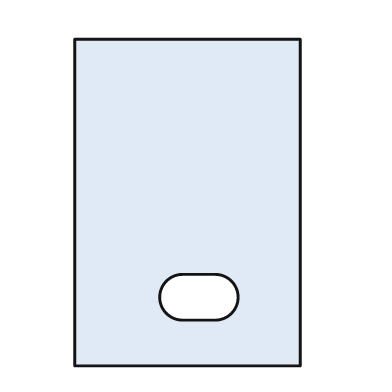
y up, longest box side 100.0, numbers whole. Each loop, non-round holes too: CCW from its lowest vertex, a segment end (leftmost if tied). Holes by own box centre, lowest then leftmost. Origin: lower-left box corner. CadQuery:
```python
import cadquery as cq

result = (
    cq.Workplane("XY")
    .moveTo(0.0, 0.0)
    .lineTo(69.0, 0.0)
    .lineTo(69.0, 100.0)
    .lineTo(0.0, 100.0)
    .close()
    .moveTo(33.0, 14.0)
    .lineTo(43.0, 14.0)
    .threePointArc((50.0, 21.0), (43.0, 28.0))
    .lineTo(33.0, 28.0)
    .threePointArc((26.0, 21.0), (33.0, 14.0))
    .close()
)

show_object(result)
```